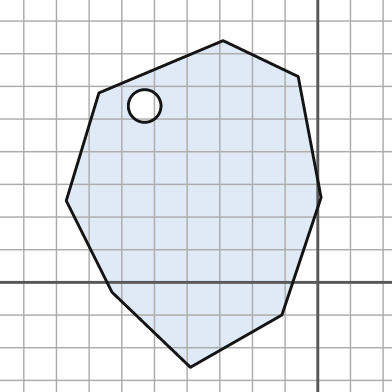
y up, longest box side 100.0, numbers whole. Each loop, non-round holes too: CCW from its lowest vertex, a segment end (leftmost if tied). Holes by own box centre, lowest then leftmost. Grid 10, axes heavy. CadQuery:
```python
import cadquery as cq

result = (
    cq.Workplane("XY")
    .moveTo(-39.0, -26.0)
    .lineTo(-11.0, -10.0)
    .lineTo(1.0, 26.0)
    .lineTo(-6.0, 63.0)
    .lineTo(-29.0, 74.0)
    .lineTo(-67.0, 58.0)
    .lineTo(-77.0, 25.0)
    .lineTo(-63.0, -3.0)
    .close()
    .moveTo(-53.0, 54.0)
    .circle(5.0)
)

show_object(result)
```